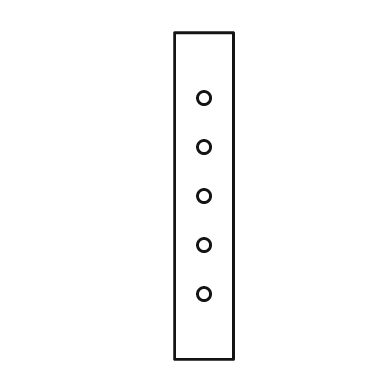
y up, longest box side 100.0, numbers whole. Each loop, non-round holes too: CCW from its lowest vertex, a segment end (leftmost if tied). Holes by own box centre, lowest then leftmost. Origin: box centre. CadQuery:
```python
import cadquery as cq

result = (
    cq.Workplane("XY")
    .moveTo(-9.0, -50.0)
    .lineTo(9.0, -50.0)
    .lineTo(9.0, 50.0)
    .lineTo(-9.0, 50.0)
    .close()
    .moveTo(0.0, -30.0)
    .circle(2.0)
    .moveTo(0.0, -15.0)
    .circle(2.0)
    .moveTo(0.0, 0.0)
    .circle(2.0)
    .moveTo(0.0, 15.0)
    .circle(2.0)
    .moveTo(0.0, 30.0)
    .circle(2.0)
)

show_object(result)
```